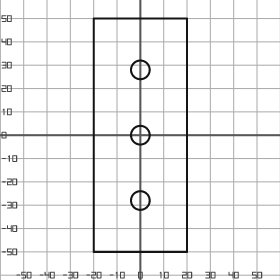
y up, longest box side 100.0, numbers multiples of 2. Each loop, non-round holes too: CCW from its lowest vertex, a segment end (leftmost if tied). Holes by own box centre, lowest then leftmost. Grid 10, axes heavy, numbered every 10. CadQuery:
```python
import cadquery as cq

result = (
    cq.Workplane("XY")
    .moveTo(-20.0, -50.0)
    .lineTo(20.0, -50.0)
    .lineTo(20.0, 50.0)
    .lineTo(-20.0, 50.0)
    .close()
    .moveTo(0.0, -28.0)
    .circle(4.0)
    .moveTo(0.0, 0.0)
    .circle(4.0)
    .moveTo(0.0, 28.0)
    .circle(4.0)
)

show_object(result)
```